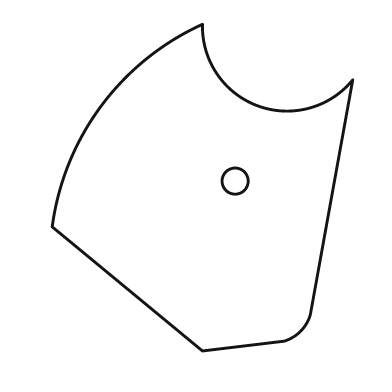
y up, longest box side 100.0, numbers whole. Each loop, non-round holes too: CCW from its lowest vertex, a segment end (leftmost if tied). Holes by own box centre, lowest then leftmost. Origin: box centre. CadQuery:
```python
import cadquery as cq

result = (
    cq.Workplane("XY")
    .moveTo(0.0, -50.0)
    .lineTo(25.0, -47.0)
    .threePointArc((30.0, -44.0), (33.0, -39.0))
    .lineTo(46.0, 33.0)
    .threePointArc((17.0, 25.0), (0.0, 50.0))
    .threePointArc((-31.0, 25.0), (-46.0, -12.0))
    .close()
    .moveTo(10.0, 2.0)
    .circle(4.0)
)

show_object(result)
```